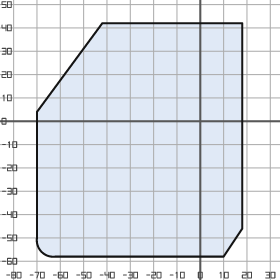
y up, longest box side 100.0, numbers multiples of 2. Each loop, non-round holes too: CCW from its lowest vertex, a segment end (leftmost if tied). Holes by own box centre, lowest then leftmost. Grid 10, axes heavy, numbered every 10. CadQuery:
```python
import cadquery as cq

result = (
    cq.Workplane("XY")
    .moveTo(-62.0, -58.0)
    .lineTo(10.0, -58.0)
    .lineTo(18.0, -46.0)
    .lineTo(18.0, 42.0)
    .lineTo(-42.0, 42.0)
    .lineTo(-70.0, 4.0)
    .lineTo(-70.0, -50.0)
    .threePointArc((-68.0, -56.0), (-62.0, -58.0))
    .close()
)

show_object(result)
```